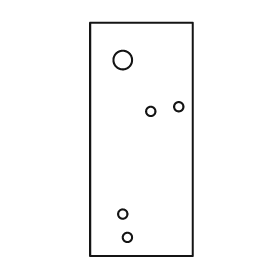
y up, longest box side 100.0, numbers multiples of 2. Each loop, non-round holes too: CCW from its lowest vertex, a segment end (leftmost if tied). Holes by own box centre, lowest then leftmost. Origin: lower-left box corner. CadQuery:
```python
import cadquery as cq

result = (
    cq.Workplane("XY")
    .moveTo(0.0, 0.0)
    .lineTo(44.0, 0.0)
    .lineTo(44.0, 100.0)
    .lineTo(0.0, 100.0)
    .close()
    .moveTo(16.0, 8.0)
    .circle(2.0)
    .moveTo(14.0, 18.0)
    .circle(2.0)
    .moveTo(26.0, 62.0)
    .circle(2.0)
    .moveTo(38.0, 64.0)
    .circle(2.0)
    .moveTo(14.0, 84.0)
    .circle(4.0)
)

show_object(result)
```